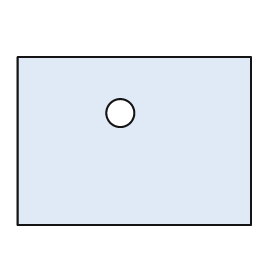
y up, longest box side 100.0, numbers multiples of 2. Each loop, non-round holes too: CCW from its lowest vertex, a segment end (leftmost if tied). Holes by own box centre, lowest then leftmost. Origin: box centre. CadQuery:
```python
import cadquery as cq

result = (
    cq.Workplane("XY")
    .moveTo(-50.0, -36.0)
    .lineTo(50.0, -36.0)
    .lineTo(50.0, 36.0)
    .lineTo(-50.0, 36.0)
    .close()
    .moveTo(-6.0, 12.0)
    .circle(6.0)
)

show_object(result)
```